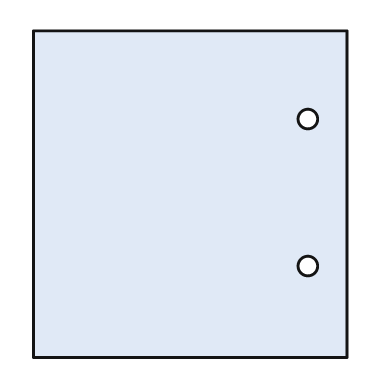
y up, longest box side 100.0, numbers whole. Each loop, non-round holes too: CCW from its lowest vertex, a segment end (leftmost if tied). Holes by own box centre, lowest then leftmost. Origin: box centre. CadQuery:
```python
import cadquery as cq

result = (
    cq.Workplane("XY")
    .moveTo(-48.0, -50.0)
    .lineTo(48.0, -50.0)
    .lineTo(48.0, 50.0)
    .lineTo(-48.0, 50.0)
    .close()
    .moveTo(36.0, -22.0)
    .circle(3.0)
    .moveTo(36.0, 23.0)
    .circle(3.0)
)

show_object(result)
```